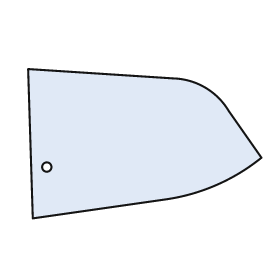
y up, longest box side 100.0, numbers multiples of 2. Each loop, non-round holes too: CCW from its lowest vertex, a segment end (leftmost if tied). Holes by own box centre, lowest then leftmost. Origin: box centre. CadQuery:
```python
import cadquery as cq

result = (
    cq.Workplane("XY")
    .moveTo(-48.0, -32.0)
    .lineTo(8.0, -24.0)
    .threePointArc((30.0, -18.0), (50.0, -6.0))
    .lineTo(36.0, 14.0)
    .threePointArc((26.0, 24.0), (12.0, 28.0))
    .lineTo(-50.0, 32.0)
    .close()
    .moveTo(-42.0, -10.0)
    .circle(2.0)
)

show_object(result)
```